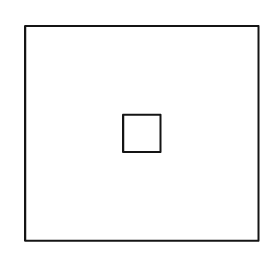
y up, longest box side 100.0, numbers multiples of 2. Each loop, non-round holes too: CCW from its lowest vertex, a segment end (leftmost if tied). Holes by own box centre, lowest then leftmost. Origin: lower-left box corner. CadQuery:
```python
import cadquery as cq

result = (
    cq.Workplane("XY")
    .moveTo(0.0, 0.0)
    .lineTo(100.0, 0.0)
    .lineTo(100.0, 92.0)
    .lineTo(0.0, 92.0)
    .close()
    .moveTo(42.0, 38.0)
    .lineTo(58.0, 38.0)
    .lineTo(58.0, 54.0)
    .lineTo(42.0, 54.0)
    .close()
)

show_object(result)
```